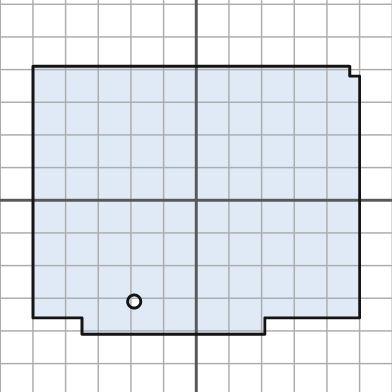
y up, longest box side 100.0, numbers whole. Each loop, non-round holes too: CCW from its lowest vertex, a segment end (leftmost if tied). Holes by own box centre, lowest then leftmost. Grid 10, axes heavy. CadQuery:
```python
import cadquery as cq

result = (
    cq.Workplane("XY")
    .moveTo(-35.0, -41.0)
    .lineTo(21.0, -41.0)
    .lineTo(21.0, -36.0)
    .lineTo(50.0, -36.0)
    .lineTo(50.0, 38.0)
    .lineTo(47.0, 38.0)
    .lineTo(47.0, 41.0)
    .lineTo(-50.0, 41.0)
    .lineTo(-50.0, -36.0)
    .lineTo(-35.0, -36.0)
    .close()
    .moveTo(-19.0, -31.0)
    .circle(2.0)
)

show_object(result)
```